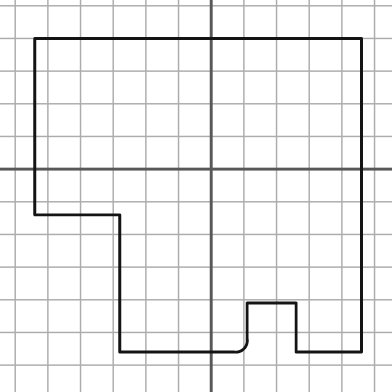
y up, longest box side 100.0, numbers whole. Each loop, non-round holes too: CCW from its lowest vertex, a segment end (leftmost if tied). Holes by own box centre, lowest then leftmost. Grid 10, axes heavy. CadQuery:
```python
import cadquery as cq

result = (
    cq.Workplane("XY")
    .moveTo(-28.0, -56.0)
    .lineTo(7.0, -56.0)
    .threePointArc((10.0, -55.0), (11.0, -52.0))
    .lineTo(11.0, -41.0)
    .lineTo(26.0, -41.0)
    .lineTo(26.0, -56.0)
    .lineTo(46.0, -56.0)
    .lineTo(46.0, 40.0)
    .lineTo(-54.0, 40.0)
    .lineTo(-54.0, -14.0)
    .lineTo(-28.0, -14.0)
    .close()
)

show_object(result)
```